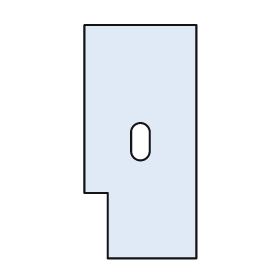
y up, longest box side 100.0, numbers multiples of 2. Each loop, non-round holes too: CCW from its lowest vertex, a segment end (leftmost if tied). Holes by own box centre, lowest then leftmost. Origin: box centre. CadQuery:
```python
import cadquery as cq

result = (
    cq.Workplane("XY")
    .moveTo(-14.0, -50.0)
    .lineTo(24.0, -50.0)
    .lineTo(24.0, 50.0)
    .lineTo(-24.0, 50.0)
    .lineTo(-24.0, -22.0)
    .lineTo(-14.0, -22.0)
    .close()
    .moveTo(-4.0, -4.0)
    .threePointArc((0.0, -8.0), (4.0, -4.0))
    .lineTo(4.0, 4.0)
    .threePointArc((0.0, 8.0), (-4.0, 4.0))
    .close()
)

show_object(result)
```